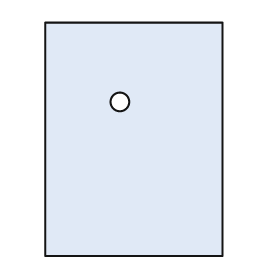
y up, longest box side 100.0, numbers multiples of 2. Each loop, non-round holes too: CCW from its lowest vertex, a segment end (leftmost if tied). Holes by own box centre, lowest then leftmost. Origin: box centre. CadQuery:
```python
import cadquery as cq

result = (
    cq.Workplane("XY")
    .moveTo(-38.0, -50.0)
    .lineTo(38.0, -50.0)
    .lineTo(38.0, 50.0)
    .lineTo(-38.0, 50.0)
    .close()
    .moveTo(-6.0, 16.0)
    .circle(4.0)
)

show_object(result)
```